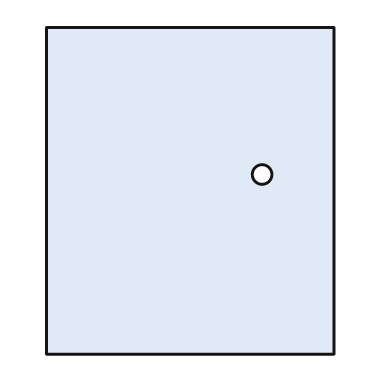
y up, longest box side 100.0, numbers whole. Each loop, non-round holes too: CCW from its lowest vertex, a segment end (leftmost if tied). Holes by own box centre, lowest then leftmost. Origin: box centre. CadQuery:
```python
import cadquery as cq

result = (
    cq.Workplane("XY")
    .moveTo(-44.0, -50.0)
    .lineTo(44.0, -50.0)
    .lineTo(44.0, 50.0)
    .lineTo(-44.0, 50.0)
    .close()
    .moveTo(22.0, 5.0)
    .circle(3.0)
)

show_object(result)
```